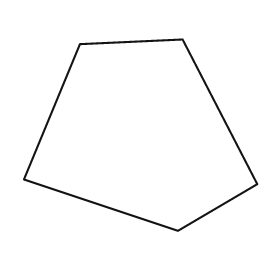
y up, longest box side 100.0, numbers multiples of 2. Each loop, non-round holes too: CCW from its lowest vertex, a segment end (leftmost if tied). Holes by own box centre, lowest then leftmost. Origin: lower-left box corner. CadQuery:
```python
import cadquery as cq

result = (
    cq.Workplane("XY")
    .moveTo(66.0, 0.0)
    .lineTo(100.0, 20.0)
    .lineTo(68.0, 82.0)
    .lineTo(24.0, 80.0)
    .lineTo(0.0, 22.0)
    .close()
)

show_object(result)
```